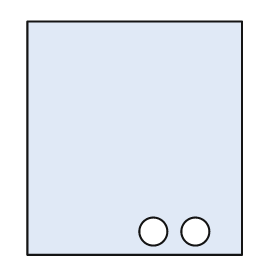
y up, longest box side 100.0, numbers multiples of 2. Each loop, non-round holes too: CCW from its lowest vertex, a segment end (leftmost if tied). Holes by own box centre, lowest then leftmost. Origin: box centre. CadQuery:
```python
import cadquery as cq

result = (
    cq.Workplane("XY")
    .moveTo(-46.0, -50.0)
    .lineTo(46.0, -50.0)
    .lineTo(46.0, 50.0)
    .lineTo(-46.0, 50.0)
    .close()
    .moveTo(8.0, -40.0)
    .circle(6.0)
    .moveTo(26.0, -40.0)
    .circle(6.0)
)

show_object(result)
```